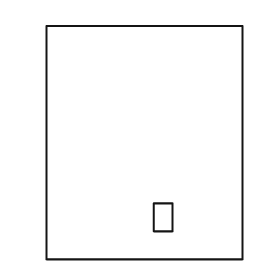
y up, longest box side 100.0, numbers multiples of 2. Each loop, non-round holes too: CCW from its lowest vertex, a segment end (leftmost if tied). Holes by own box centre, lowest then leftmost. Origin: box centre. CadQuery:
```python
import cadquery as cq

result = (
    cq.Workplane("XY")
    .moveTo(-42.0, -50.0)
    .lineTo(42.0, -50.0)
    .lineTo(42.0, 50.0)
    .lineTo(-42.0, 50.0)
    .close()
    .moveTo(4.0, -38.0)
    .lineTo(12.0, -38.0)
    .lineTo(12.0, -26.0)
    .lineTo(4.0, -26.0)
    .close()
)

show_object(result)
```